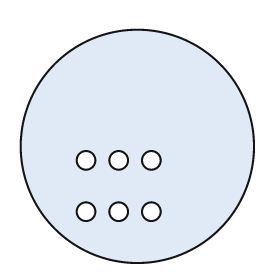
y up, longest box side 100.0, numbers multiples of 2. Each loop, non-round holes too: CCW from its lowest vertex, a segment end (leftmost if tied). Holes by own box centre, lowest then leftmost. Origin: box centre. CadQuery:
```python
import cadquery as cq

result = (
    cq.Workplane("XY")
    .moveTo(0.0, 0.0)
    .circle(50.0)
    .moveTo(-22.0, -28.0)
    .circle(4.0)
    .moveTo(-8.0, -28.0)
    .circle(4.0)
    .moveTo(6.0, -28.0)
    .circle(4.0)
    .moveTo(-22.0, -6.0)
    .circle(4.0)
    .moveTo(-8.0, -6.0)
    .circle(4.0)
    .moveTo(6.0, -6.0)
    .circle(4.0)
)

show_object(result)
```